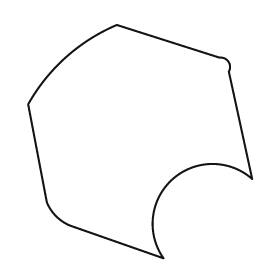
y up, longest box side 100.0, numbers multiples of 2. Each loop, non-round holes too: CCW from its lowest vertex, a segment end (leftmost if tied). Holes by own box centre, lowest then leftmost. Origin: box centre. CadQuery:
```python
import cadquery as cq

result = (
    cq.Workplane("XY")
    .moveTo(10.0, -50.0)
    .threePointArc((14.0, -16.0), (48.0, -16.0))
    .lineTo(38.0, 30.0)
    .threePointArc((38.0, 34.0), (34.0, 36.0))
    .lineTo(-10.0, 50.0)
    .threePointArc((-32.0, 36.0), (-48.0, 16.0))
    .lineTo(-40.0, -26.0)
    .threePointArc((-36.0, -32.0), (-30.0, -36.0))
    .close()
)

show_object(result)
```